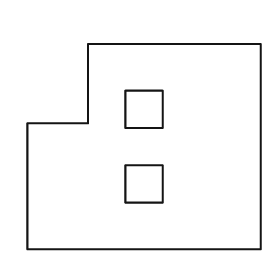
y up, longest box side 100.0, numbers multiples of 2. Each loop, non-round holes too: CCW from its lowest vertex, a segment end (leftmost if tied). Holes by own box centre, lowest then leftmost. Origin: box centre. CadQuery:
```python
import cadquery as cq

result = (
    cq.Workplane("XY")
    .moveTo(-50.0, -44.0)
    .lineTo(50.0, -44.0)
    .lineTo(50.0, 44.0)
    .lineTo(-24.0, 44.0)
    .lineTo(-24.0, 10.0)
    .lineTo(-50.0, 10.0)
    .close()
    .moveTo(-8.0, -24.0)
    .lineTo(8.0, -24.0)
    .lineTo(8.0, -8.0)
    .lineTo(-8.0, -8.0)
    .close()
    .moveTo(-8.0, 8.0)
    .lineTo(8.0, 8.0)
    .lineTo(8.0, 24.0)
    .lineTo(-8.0, 24.0)
    .close()
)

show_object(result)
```